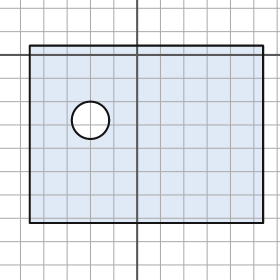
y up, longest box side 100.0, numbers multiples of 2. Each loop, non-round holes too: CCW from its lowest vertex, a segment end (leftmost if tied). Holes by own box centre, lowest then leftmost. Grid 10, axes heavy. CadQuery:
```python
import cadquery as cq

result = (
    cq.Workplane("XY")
    .moveTo(-46.0, -72.0)
    .lineTo(54.0, -72.0)
    .lineTo(54.0, 4.0)
    .lineTo(-46.0, 4.0)
    .close()
    .moveTo(-20.0, -28.0)
    .circle(8.0)
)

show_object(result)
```